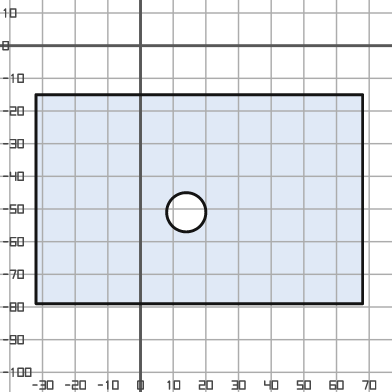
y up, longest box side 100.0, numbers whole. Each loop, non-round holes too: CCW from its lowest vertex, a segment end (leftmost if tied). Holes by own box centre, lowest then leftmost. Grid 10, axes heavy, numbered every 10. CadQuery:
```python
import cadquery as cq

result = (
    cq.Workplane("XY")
    .moveTo(-32.0, -79.0)
    .lineTo(68.0, -79.0)
    .lineTo(68.0, -15.0)
    .lineTo(-32.0, -15.0)
    .close()
    .moveTo(14.0, -51.0)
    .circle(6.0)
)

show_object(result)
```